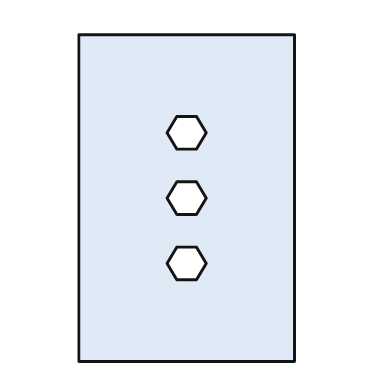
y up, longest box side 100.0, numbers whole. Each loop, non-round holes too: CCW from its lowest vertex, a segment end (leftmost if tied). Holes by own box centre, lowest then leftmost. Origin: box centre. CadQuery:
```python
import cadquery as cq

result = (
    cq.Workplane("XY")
    .moveTo(-33.0, -50.0)
    .lineTo(33.0, -50.0)
    .lineTo(33.0, 50.0)
    .lineTo(-33.0, 50.0)
    .close()
    .moveTo(-3.0, -25.0)
    .lineTo(3.0, -25.0)
    .lineTo(6.0, -20.0)
    .lineTo(3.0, -15.0)
    .lineTo(-3.0, -15.0)
    .lineTo(-6.0, -20.0)
    .close()
    .moveTo(-3.0, -5.0)
    .lineTo(3.0, -5.0)
    .lineTo(6.0, 0.0)
    .lineTo(3.0, 5.0)
    .lineTo(-3.0, 5.0)
    .lineTo(-6.0, 0.0)
    .close()
    .moveTo(-3.0, 15.0)
    .lineTo(3.0, 15.0)
    .lineTo(6.0, 20.0)
    .lineTo(3.0, 25.0)
    .lineTo(-3.0, 25.0)
    .lineTo(-6.0, 20.0)
    .close()
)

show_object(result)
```